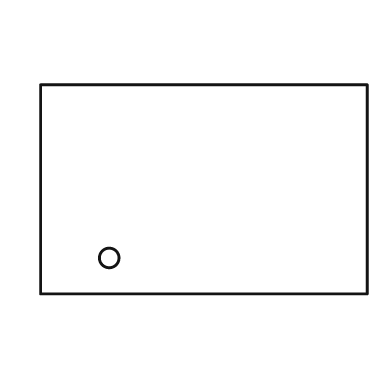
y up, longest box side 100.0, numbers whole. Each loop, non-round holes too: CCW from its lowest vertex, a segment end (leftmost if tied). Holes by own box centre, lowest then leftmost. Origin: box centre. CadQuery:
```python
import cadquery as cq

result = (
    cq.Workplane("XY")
    .moveTo(-50.0, -32.0)
    .lineTo(50.0, -32.0)
    .lineTo(50.0, 32.0)
    .lineTo(-50.0, 32.0)
    .close()
    .moveTo(-29.0, -21.0)
    .circle(3.0)
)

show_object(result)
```